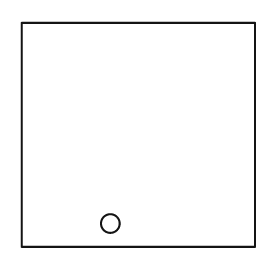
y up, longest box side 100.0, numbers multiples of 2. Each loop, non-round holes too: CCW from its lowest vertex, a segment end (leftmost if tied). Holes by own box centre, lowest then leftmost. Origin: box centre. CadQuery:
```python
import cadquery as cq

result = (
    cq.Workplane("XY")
    .moveTo(-50.0, -48.0)
    .lineTo(50.0, -48.0)
    .lineTo(50.0, 48.0)
    .lineTo(-50.0, 48.0)
    .close()
    .moveTo(-12.0, -38.0)
    .circle(4.0)
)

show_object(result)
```